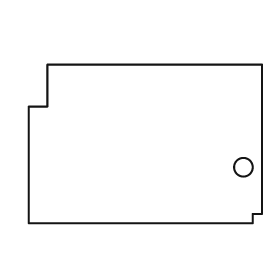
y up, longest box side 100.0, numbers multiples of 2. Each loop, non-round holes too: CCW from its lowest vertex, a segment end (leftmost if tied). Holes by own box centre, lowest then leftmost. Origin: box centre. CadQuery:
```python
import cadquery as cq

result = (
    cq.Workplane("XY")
    .moveTo(-50.0, -34.0)
    .lineTo(46.0, -34.0)
    .lineTo(46.0, -30.0)
    .lineTo(50.0, -30.0)
    .lineTo(50.0, 34.0)
    .lineTo(-42.0, 34.0)
    .lineTo(-42.0, 16.0)
    .lineTo(-50.0, 16.0)
    .close()
    .moveTo(42.0, -10.0)
    .circle(4.0)
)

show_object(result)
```